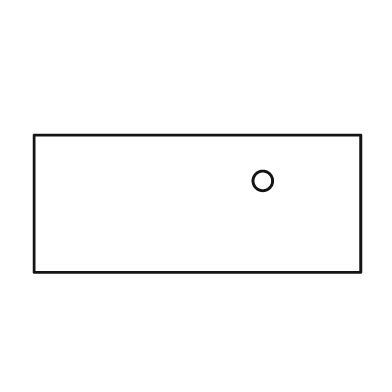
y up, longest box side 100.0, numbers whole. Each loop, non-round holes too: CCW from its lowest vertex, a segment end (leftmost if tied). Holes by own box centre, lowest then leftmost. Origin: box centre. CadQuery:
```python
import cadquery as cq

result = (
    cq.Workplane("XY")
    .moveTo(-50.0, -21.0)
    .lineTo(50.0, -21.0)
    .lineTo(50.0, 21.0)
    .lineTo(-50.0, 21.0)
    .close()
    .moveTo(20.0, 7.0)
    .circle(3.0)
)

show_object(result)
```